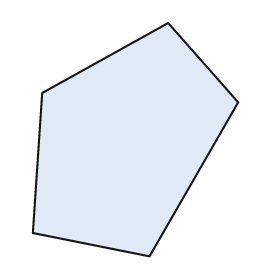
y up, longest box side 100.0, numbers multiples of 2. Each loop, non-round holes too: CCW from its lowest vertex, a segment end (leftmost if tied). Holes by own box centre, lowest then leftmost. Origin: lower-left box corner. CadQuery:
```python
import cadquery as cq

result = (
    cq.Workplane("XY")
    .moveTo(50.0, 0.0)
    .lineTo(88.0, 66.0)
    .lineTo(58.0, 100.0)
    .lineTo(4.0, 70.0)
    .lineTo(0.0, 10.0)
    .close()
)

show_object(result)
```